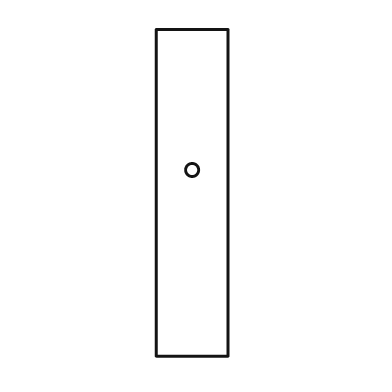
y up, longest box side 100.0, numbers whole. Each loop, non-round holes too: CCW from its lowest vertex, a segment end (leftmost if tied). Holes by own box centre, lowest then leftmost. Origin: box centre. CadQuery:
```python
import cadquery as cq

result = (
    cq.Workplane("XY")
    .moveTo(-11.0, -50.0)
    .lineTo(11.0, -50.0)
    .lineTo(11.0, 50.0)
    .lineTo(-11.0, 50.0)
    .close()
    .moveTo(0.0, 7.0)
    .circle(2.0)
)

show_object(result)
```